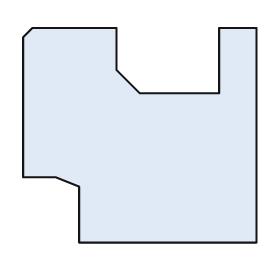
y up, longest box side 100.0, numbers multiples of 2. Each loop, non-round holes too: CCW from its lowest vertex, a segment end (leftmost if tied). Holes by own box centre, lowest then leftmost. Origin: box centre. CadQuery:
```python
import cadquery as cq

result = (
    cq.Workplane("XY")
    .moveTo(-26.0, -46.0)
    .lineTo(50.0, -46.0)
    .lineTo(50.0, 46.0)
    .lineTo(34.0, 46.0)
    .lineTo(34.0, 18.0)
    .lineTo(0.0, 18.0)
    .lineTo(-10.0, 28.0)
    .lineTo(-10.0, 46.0)
    .lineTo(-46.0, 46.0)
    .lineTo(-50.0, 42.0)
    .lineTo(-50.0, -18.0)
    .lineTo(-36.0, -18.0)
    .lineTo(-26.0, -22.0)
    .close()
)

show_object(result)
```